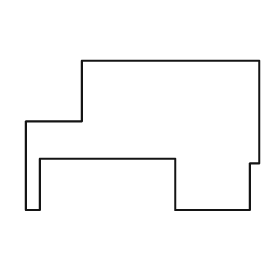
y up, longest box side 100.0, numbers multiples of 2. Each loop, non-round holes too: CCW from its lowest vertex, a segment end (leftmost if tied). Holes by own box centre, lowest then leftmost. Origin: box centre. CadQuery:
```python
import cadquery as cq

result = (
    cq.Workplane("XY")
    .moveTo(-50.0, -32.0)
    .lineTo(-44.0, -32.0)
    .lineTo(-44.0, -10.0)
    .lineTo(14.0, -10.0)
    .lineTo(14.0, -32.0)
    .lineTo(46.0, -32.0)
    .lineTo(46.0, -12.0)
    .lineTo(50.0, -12.0)
    .lineTo(50.0, 32.0)
    .lineTo(-26.0, 32.0)
    .lineTo(-26.0, 6.0)
    .lineTo(-50.0, 6.0)
    .close()
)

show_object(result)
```